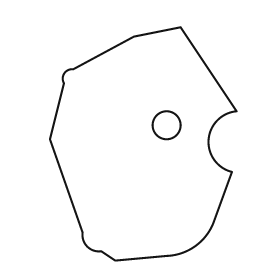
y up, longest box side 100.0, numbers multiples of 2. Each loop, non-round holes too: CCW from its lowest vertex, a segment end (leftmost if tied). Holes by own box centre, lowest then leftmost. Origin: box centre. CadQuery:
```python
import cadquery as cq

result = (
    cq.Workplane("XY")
    .moveTo(-12.0, -50.0)
    .lineTo(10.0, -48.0)
    .threePointArc((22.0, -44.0), (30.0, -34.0))
    .lineTo(38.0, -12.0)
    .threePointArc((28.0, 2.0), (40.0, 14.0))
    .lineTo(16.0, 50.0)
    .lineTo(-4.0, 46.0)
    .lineTo(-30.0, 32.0)
    .threePointArc((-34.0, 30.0), (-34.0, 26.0))
    .lineTo(-40.0, 2.0)
    .lineTo(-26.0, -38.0)
    .threePointArc((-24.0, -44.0), (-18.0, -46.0))
    .close()
    .moveTo(10.0, 8.0)
    .circle(6.0)
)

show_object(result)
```